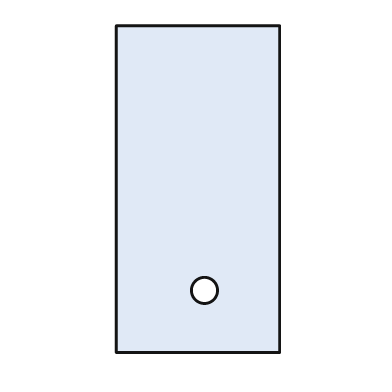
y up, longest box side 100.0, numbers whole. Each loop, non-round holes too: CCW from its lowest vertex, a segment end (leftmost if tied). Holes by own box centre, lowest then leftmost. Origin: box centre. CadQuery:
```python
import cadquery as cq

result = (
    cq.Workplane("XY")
    .moveTo(-25.0, -50.0)
    .lineTo(25.0, -50.0)
    .lineTo(25.0, 50.0)
    .lineTo(-25.0, 50.0)
    .close()
    .moveTo(2.0, -31.0)
    .circle(4.0)
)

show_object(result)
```